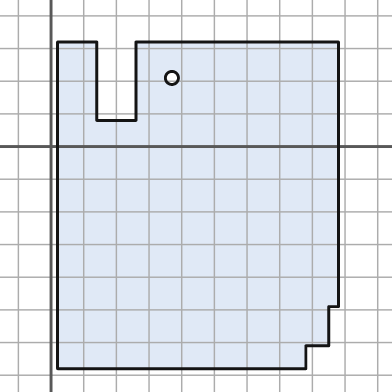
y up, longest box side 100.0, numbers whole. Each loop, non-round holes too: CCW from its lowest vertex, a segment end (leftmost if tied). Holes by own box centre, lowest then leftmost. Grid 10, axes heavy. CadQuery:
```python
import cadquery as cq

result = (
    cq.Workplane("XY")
    .moveTo(2.0, -68.0)
    .lineTo(78.0, -68.0)
    .lineTo(78.0, -61.0)
    .lineTo(85.0, -61.0)
    .lineTo(85.0, -49.0)
    .lineTo(88.0, -49.0)
    .lineTo(88.0, 32.0)
    .lineTo(26.0, 32.0)
    .lineTo(26.0, 8.0)
    .lineTo(14.0, 8.0)
    .lineTo(14.0, 32.0)
    .lineTo(2.0, 32.0)
    .close()
    .moveTo(37.0, 21.0)
    .circle(2.0)
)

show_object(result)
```